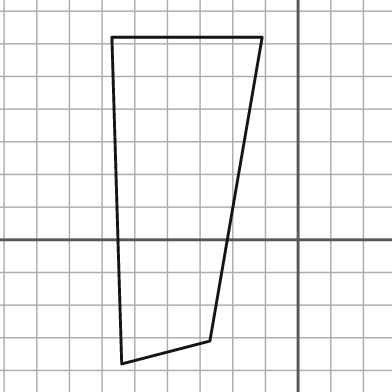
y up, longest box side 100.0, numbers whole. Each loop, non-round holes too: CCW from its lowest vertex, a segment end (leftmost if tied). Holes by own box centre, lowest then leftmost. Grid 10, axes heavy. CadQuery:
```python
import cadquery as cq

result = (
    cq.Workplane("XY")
    .moveTo(-54.0, -38.0)
    .lineTo(-27.0, -31.0)
    .lineTo(-11.0, 62.0)
    .lineTo(-57.0, 62.0)
    .close()
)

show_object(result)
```